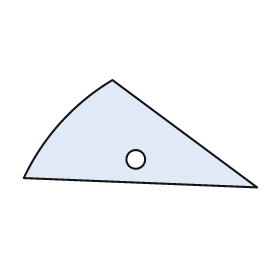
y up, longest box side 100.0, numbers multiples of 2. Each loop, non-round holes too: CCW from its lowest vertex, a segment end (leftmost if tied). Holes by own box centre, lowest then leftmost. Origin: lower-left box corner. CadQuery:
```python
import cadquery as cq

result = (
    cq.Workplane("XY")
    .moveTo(100.0, 0.0)
    .lineTo(38.0, 46.0)
    .threePointArc((16.0, 28.0), (0.0, 4.0))
    .close()
    .moveTo(48.0, 12.0)
    .circle(4.0)
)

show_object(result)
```